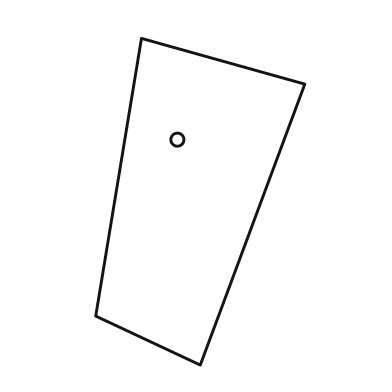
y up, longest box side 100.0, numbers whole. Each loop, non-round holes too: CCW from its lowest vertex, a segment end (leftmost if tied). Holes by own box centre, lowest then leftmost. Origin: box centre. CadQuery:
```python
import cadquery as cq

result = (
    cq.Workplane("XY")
    .moveTo(0.0, -50.0)
    .lineTo(32.0, 36.0)
    .lineTo(-18.0, 50.0)
    .lineTo(-32.0, -35.0)
    .close()
    .moveTo(-7.0, 19.0)
    .circle(2.0)
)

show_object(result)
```